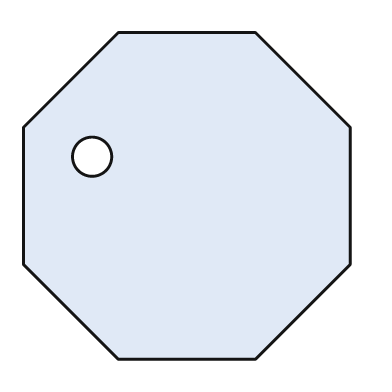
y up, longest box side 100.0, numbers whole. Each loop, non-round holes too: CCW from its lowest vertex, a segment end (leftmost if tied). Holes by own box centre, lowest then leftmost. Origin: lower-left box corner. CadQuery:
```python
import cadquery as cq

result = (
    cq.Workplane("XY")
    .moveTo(29.0, 0.0)
    .lineTo(71.0, 0.0)
    .lineTo(100.0, 29.0)
    .lineTo(100.0, 71.0)
    .lineTo(71.0, 100.0)
    .lineTo(29.0, 100.0)
    .lineTo(0.0, 71.0)
    .lineTo(0.0, 29.0)
    .close()
    .moveTo(21.0, 62.0)
    .circle(6.0)
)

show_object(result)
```